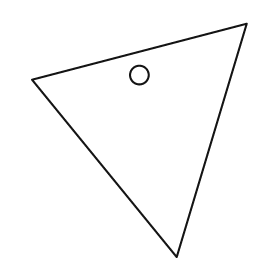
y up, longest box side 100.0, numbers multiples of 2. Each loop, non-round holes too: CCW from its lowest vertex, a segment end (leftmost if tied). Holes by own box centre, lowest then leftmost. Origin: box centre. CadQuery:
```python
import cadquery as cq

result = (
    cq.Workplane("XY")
    .moveTo(16.0, -50.0)
    .lineTo(46.0, 50.0)
    .lineTo(-46.0, 26.0)
    .close()
    .moveTo(0.0, 28.0)
    .circle(4.0)
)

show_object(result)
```